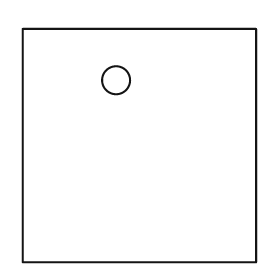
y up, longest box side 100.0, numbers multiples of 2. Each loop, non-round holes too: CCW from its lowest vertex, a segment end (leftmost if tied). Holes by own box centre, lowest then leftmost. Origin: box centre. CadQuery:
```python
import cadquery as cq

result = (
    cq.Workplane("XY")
    .moveTo(-50.0, -50.0)
    .lineTo(50.0, -50.0)
    .lineTo(50.0, 50.0)
    .lineTo(-50.0, 50.0)
    .close()
    .moveTo(-10.0, 28.0)
    .circle(6.0)
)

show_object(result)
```